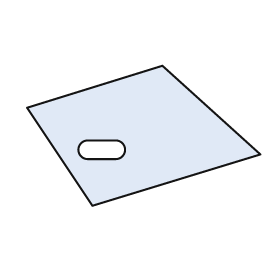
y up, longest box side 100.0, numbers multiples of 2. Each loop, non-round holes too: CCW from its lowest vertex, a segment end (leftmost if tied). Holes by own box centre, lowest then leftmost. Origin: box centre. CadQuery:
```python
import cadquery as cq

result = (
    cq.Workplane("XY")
    .moveTo(-22.0, -30.0)
    .lineTo(50.0, -8.0)
    .lineTo(8.0, 30.0)
    .lineTo(-50.0, 12.0)
    .close()
    .moveTo(-24.0, -10.0)
    .lineTo(-12.0, -10.0)
    .threePointArc((-8.0, -6.0), (-12.0, -2.0))
    .lineTo(-24.0, -2.0)
    .threePointArc((-28.0, -6.0), (-24.0, -10.0))
    .close()
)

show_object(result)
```